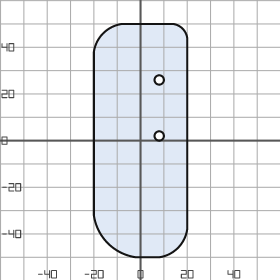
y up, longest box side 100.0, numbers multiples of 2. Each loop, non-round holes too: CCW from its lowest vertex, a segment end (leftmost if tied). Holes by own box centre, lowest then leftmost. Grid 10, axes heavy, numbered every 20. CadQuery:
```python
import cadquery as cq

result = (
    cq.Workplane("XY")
    .moveTo(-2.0, -50.0)
    .lineTo(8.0, -50.0)
    .threePointArc((16.0, -46.0), (20.0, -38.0))
    .lineTo(20.0, 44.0)
    .threePointArc((18.0, 48.0), (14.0, 50.0))
    .lineTo(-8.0, 50.0)
    .threePointArc((-16.0, 46.0), (-20.0, 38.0))
    .lineTo(-20.0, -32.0)
    .threePointArc((-14.0, -44.0), (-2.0, -50.0))
    .close()
    .moveTo(8.0, 2.0)
    .circle(2.0)
    .moveTo(8.0, 26.0)
    .circle(2.0)
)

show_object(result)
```